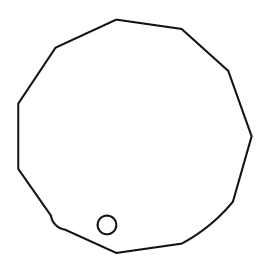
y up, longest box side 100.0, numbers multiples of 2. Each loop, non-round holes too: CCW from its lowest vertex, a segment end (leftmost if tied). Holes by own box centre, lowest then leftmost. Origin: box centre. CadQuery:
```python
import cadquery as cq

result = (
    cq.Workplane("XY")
    .moveTo(-8.0, -50.0)
    .lineTo(20.0, -46.0)
    .threePointArc((32.0, -38.0), (42.0, -28.0))
    .lineTo(50.0, 0.0)
    .lineTo(40.0, 28.0)
    .lineTo(20.0, 46.0)
    .lineTo(-8.0, 50.0)
    .lineTo(-34.0, 38.0)
    .lineTo(-50.0, 14.0)
    .lineTo(-50.0, -14.0)
    .lineTo(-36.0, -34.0)
    .threePointArc((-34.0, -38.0), (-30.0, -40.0))
    .close()
    .moveTo(-12.0, -38.0)
    .circle(4.0)
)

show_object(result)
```